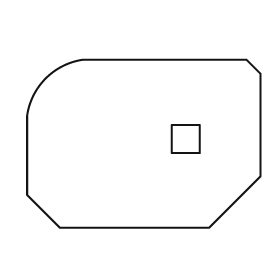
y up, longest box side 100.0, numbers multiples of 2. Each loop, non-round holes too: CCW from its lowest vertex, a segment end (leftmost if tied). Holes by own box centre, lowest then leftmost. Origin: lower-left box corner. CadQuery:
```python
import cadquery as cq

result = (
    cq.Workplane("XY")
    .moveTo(14.0, 0.0)
    .lineTo(78.0, 0.0)
    .lineTo(100.0, 22.0)
    .lineTo(100.0, 66.0)
    .lineTo(94.0, 72.0)
    .lineTo(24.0, 72.0)
    .threePointArc((8.0, 64.0), (0.0, 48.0))
    .lineTo(0.0, 14.0)
    .close()
    .moveTo(62.0, 32.0)
    .lineTo(74.0, 32.0)
    .lineTo(74.0, 44.0)
    .lineTo(62.0, 44.0)
    .close()
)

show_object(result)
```